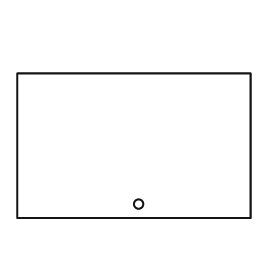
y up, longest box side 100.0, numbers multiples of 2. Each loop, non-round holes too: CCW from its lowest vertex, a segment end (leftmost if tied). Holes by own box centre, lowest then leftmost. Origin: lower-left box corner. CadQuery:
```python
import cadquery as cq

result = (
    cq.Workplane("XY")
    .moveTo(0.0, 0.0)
    .lineTo(100.0, 0.0)
    .lineTo(100.0, 62.0)
    .lineTo(0.0, 62.0)
    .close()
    .moveTo(52.0, 6.0)
    .circle(2.0)
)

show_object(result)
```